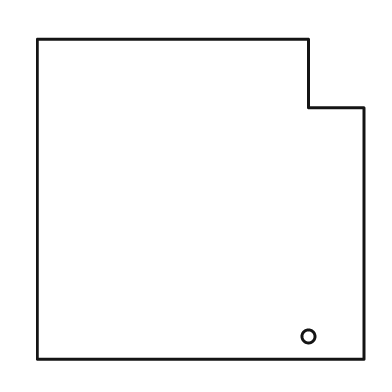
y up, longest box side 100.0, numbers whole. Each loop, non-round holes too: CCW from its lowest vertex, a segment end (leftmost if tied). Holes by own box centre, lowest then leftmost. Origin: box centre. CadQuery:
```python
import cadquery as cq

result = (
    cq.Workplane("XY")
    .moveTo(-50.0, -49.0)
    .lineTo(50.0, -49.0)
    .lineTo(50.0, 28.0)
    .lineTo(33.0, 28.0)
    .lineTo(33.0, 49.0)
    .lineTo(-50.0, 49.0)
    .close()
    .moveTo(33.0, -42.0)
    .circle(2.0)
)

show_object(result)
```